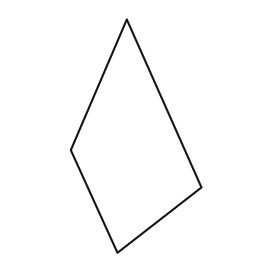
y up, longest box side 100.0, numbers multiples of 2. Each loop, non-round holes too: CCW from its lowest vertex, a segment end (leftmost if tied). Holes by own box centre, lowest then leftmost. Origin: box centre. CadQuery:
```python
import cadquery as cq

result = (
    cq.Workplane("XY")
    .moveTo(-8.0, -50.0)
    .lineTo(28.0, -22.0)
    .lineTo(-4.0, 50.0)
    .lineTo(-28.0, -6.0)
    .close()
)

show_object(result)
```